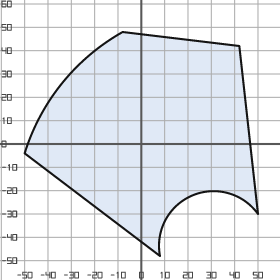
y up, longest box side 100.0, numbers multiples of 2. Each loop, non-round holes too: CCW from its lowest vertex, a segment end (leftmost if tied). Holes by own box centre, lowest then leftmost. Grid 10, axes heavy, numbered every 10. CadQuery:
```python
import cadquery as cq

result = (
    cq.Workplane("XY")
    .moveTo(8.0, -48.0)
    .threePointArc((22.0, -22.0), (50.0, -30.0))
    .lineTo(42.0, 42.0)
    .lineTo(-8.0, 48.0)
    .threePointArc((-34.0, 26.0), (-50.0, -4.0))
    .close()
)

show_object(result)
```